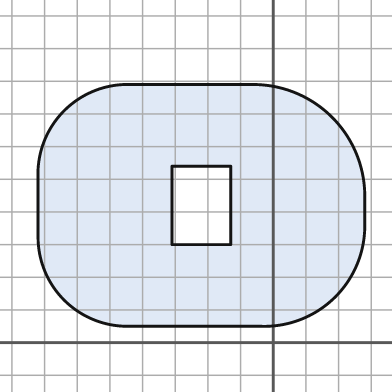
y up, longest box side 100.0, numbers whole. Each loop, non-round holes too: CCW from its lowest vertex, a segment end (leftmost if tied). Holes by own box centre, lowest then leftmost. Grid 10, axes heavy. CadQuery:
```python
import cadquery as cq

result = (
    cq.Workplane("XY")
    .moveTo(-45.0, 5.0)
    .lineTo(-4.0, 5.0)
    .threePointArc((19.0, 14.0), (28.0, 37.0))
    .lineTo(28.0, 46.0)
    .threePointArc((18.0, 69.0), (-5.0, 79.0))
    .lineTo(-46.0, 79.0)
    .threePointArc((-64.0, 71.0), (-72.0, 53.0))
    .lineTo(-72.0, 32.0)
    .threePointArc((-64.0, 13.0), (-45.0, 5.0))
    .close()
    .moveTo(-31.0, 30.0)
    .lineTo(-13.0, 30.0)
    .lineTo(-13.0, 54.0)
    .lineTo(-31.0, 54.0)
    .close()
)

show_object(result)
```